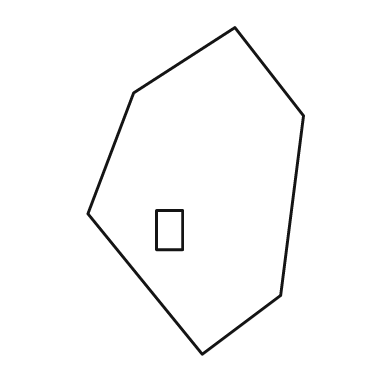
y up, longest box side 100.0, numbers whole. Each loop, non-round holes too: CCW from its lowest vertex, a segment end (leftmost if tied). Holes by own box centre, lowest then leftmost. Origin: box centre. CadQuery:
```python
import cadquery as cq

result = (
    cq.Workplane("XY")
    .moveTo(2.0, -50.0)
    .lineTo(26.0, -32.0)
    .lineTo(33.0, 23.0)
    .lineTo(12.0, 50.0)
    .lineTo(-19.0, 30.0)
    .lineTo(-33.0, -7.0)
    .close()
    .moveTo(-12.0, -18.0)
    .lineTo(-4.0, -18.0)
    .lineTo(-4.0, -6.0)
    .lineTo(-12.0, -6.0)
    .close()
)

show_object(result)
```